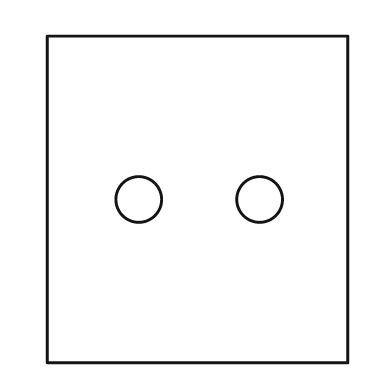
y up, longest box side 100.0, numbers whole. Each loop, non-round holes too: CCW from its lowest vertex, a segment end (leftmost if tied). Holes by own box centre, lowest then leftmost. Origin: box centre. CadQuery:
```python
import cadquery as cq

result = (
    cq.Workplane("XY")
    .moveTo(-46.0, -50.0)
    .lineTo(46.0, -50.0)
    .lineTo(46.0, 50.0)
    .lineTo(-46.0, 50.0)
    .close()
    .moveTo(-18.0, 0.0)
    .circle(7.0)
    .moveTo(19.0, 0.0)
    .circle(7.0)
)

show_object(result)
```